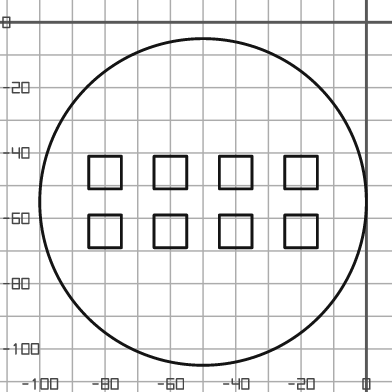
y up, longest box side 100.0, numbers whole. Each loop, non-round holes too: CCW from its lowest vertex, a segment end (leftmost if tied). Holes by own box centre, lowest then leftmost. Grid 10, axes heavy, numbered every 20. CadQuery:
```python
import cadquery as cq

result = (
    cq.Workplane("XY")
    .moveTo(-50.0, -55.0)
    .circle(50.0)
    .moveTo(-85.0, -69.0)
    .lineTo(-75.0, -69.0)
    .lineTo(-75.0, -59.0)
    .lineTo(-85.0, -59.0)
    .close()
    .moveTo(-65.0, -69.0)
    .lineTo(-55.0, -69.0)
    .lineTo(-55.0, -59.0)
    .lineTo(-65.0, -59.0)
    .close()
    .moveTo(-45.0, -69.0)
    .lineTo(-35.0, -69.0)
    .lineTo(-35.0, -59.0)
    .lineTo(-45.0, -59.0)
    .close()
    .moveTo(-25.0, -69.0)
    .lineTo(-15.0, -69.0)
    .lineTo(-15.0, -59.0)
    .lineTo(-25.0, -59.0)
    .close()
    .moveTo(-85.0, -51.0)
    .lineTo(-75.0, -51.0)
    .lineTo(-75.0, -41.0)
    .lineTo(-85.0, -41.0)
    .close()
    .moveTo(-65.0, -51.0)
    .lineTo(-55.0, -51.0)
    .lineTo(-55.0, -41.0)
    .lineTo(-65.0, -41.0)
    .close()
    .moveTo(-45.0, -51.0)
    .lineTo(-35.0, -51.0)
    .lineTo(-35.0, -41.0)
    .lineTo(-45.0, -41.0)
    .close()
    .moveTo(-25.0, -51.0)
    .lineTo(-15.0, -51.0)
    .lineTo(-15.0, -41.0)
    .lineTo(-25.0, -41.0)
    .close()
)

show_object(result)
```